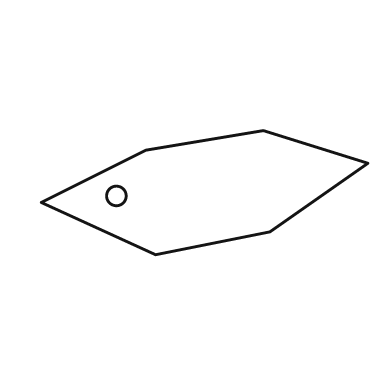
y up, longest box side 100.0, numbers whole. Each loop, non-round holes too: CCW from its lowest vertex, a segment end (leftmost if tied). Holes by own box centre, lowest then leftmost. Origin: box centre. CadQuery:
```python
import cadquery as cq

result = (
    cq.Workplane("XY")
    .moveTo(-15.0, -19.0)
    .lineTo(20.0, -12.0)
    .lineTo(50.0, 9.0)
    .lineTo(18.0, 19.0)
    .lineTo(-18.0, 13.0)
    .lineTo(-50.0, -3.0)
    .close()
    .moveTo(-27.0, -1.0)
    .circle(3.0)
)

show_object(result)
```